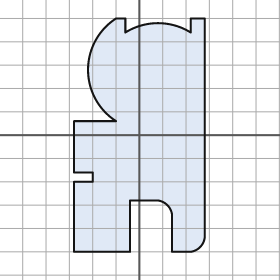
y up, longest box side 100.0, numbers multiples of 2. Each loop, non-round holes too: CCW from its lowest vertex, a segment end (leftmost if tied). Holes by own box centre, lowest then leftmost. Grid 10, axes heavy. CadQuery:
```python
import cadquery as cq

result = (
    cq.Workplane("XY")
    .moveTo(-28.0, -50.0)
    .lineTo(-4.0, -50.0)
    .lineTo(-4.0, -28.0)
    .lineTo(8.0, -28.0)
    .threePointArc((12.0, -30.0), (14.0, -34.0))
    .lineTo(14.0, -50.0)
    .lineTo(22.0, -50.0)
    .threePointArc((26.0, -48.0), (28.0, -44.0))
    .lineTo(28.0, 50.0)
    .lineTo(22.0, 50.0)
    .lineTo(22.0, 44.0)
    .threePointArc((8.0, 48.0), (-6.0, 44.0))
    .lineTo(-6.0, 50.0)
    .lineTo(-10.0, 50.0)
    .threePointArc((-22.0, 28.0), (-10.0, 6.0))
    .lineTo(-28.0, 6.0)
    .lineTo(-28.0, -16.0)
    .lineTo(-20.0, -16.0)
    .lineTo(-20.0, -20.0)
    .lineTo(-28.0, -20.0)
    .close()
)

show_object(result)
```